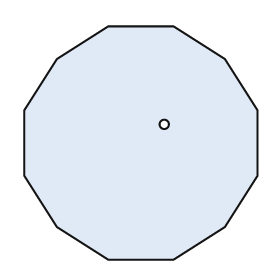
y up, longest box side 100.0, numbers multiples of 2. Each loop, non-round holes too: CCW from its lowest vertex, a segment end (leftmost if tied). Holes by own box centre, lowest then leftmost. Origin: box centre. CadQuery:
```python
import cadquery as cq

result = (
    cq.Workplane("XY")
    .moveTo(-14.0, -50.0)
    .lineTo(14.0, -50.0)
    .lineTo(36.0, -36.0)
    .lineTo(50.0, -14.0)
    .lineTo(50.0, 14.0)
    .lineTo(36.0, 36.0)
    .lineTo(14.0, 50.0)
    .lineTo(-14.0, 50.0)
    .lineTo(-36.0, 36.0)
    .lineTo(-50.0, 14.0)
    .lineTo(-50.0, -14.0)
    .lineTo(-36.0, -36.0)
    .close()
    .moveTo(10.0, 8.0)
    .circle(2.0)
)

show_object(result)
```